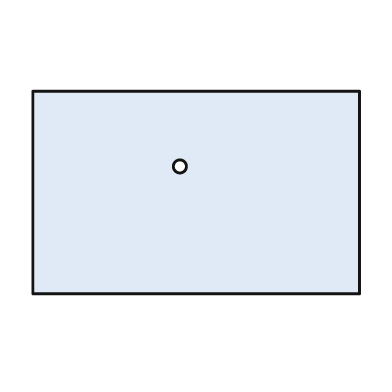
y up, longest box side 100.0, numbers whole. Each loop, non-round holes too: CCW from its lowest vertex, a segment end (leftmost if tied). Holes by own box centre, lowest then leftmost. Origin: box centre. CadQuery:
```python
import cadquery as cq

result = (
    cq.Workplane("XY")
    .moveTo(-50.0, -31.0)
    .lineTo(50.0, -31.0)
    .lineTo(50.0, 31.0)
    .lineTo(-50.0, 31.0)
    .close()
    .moveTo(-5.0, 8.0)
    .circle(2.0)
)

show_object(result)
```